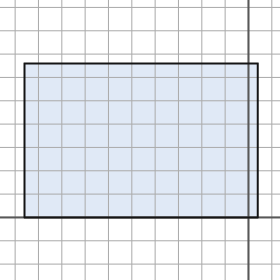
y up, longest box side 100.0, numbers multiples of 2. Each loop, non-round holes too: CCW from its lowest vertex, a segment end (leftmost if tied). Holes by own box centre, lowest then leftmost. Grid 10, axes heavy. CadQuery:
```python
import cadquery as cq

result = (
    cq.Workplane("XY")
    .moveTo(-96.0, 0.0)
    .lineTo(4.0, 0.0)
    .lineTo(4.0, 66.0)
    .lineTo(-96.0, 66.0)
    .close()
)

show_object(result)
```